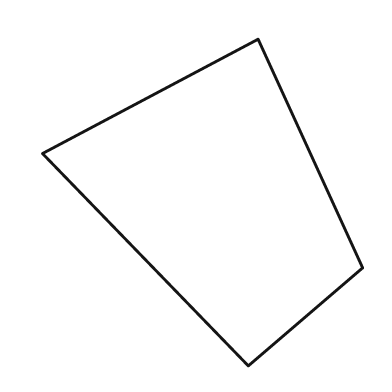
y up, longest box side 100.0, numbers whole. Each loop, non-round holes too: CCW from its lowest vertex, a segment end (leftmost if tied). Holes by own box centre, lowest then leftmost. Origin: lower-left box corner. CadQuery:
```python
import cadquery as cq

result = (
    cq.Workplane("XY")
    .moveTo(63.0, 0.0)
    .lineTo(98.0, 30.0)
    .lineTo(66.0, 100.0)
    .lineTo(0.0, 65.0)
    .close()
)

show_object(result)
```